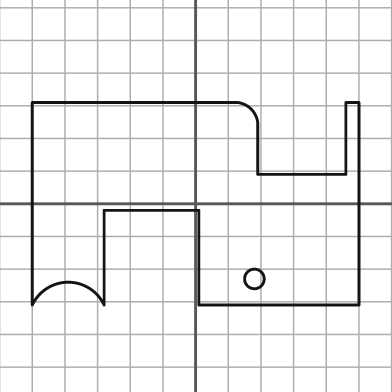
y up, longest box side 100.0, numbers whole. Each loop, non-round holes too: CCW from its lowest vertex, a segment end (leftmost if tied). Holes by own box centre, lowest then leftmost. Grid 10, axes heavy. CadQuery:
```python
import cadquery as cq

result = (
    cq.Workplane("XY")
    .moveTo(-50.0, -31.0)
    .threePointArc((-39.0, -24.0), (-28.0, -31.0))
    .lineTo(-28.0, -2.0)
    .lineTo(1.0, -2.0)
    .lineTo(1.0, -31.0)
    .lineTo(50.0, -31.0)
    .lineTo(50.0, 31.0)
    .lineTo(46.0, 31.0)
    .lineTo(46.0, 9.0)
    .lineTo(19.0, 9.0)
    .lineTo(19.0, 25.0)
    .threePointArc((17.0, 29.0), (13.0, 31.0))
    .lineTo(-50.0, 31.0)
    .close()
    .moveTo(18.0, -23.0)
    .circle(3.0)
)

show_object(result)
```